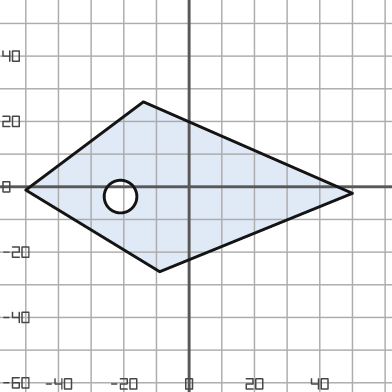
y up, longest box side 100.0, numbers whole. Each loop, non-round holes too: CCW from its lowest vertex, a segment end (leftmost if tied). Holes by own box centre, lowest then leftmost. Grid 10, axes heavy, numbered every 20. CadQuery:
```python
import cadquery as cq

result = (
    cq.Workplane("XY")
    .moveTo(-9.0, -26.0)
    .lineTo(50.0, -2.0)
    .lineTo(-14.0, 26.0)
    .lineTo(-50.0, -1.0)
    .close()
    .moveTo(-21.0, -3.0)
    .circle(5.0)
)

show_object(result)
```